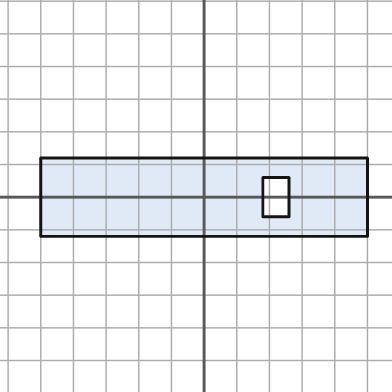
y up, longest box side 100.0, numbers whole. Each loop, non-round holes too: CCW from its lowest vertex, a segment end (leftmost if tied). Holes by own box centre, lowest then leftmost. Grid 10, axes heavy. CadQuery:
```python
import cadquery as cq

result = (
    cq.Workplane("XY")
    .moveTo(-50.0, -12.0)
    .lineTo(50.0, -12.0)
    .lineTo(50.0, 12.0)
    .lineTo(-50.0, 12.0)
    .close()
    .moveTo(18.0, -6.0)
    .lineTo(26.0, -6.0)
    .lineTo(26.0, 6.0)
    .lineTo(18.0, 6.0)
    .close()
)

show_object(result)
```